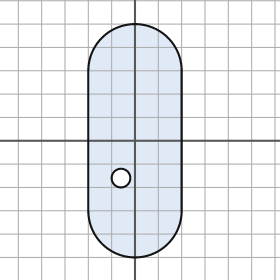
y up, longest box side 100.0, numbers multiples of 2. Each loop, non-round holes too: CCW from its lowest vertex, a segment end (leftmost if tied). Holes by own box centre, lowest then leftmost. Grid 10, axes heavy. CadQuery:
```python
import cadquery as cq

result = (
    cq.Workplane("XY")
    .moveTo(-20.0, -30.0)
    .threePointArc((0.0, -50.0), (20.0, -30.0))
    .lineTo(20.0, 30.0)
    .threePointArc((0.0, 50.0), (-20.0, 30.0))
    .close()
    .moveTo(-6.0, -16.0)
    .circle(4.0)
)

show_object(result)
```